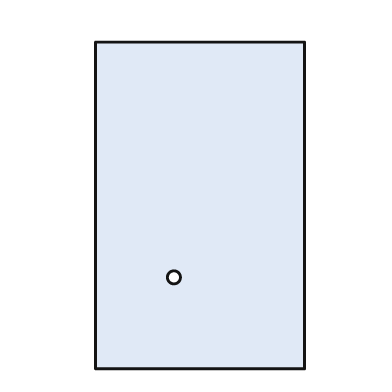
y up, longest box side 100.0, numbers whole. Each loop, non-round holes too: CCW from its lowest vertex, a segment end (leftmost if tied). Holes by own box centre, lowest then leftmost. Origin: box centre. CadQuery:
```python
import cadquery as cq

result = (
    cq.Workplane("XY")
    .moveTo(-32.0, -50.0)
    .lineTo(32.0, -50.0)
    .lineTo(32.0, 50.0)
    .lineTo(-32.0, 50.0)
    .close()
    .moveTo(-8.0, -22.0)
    .circle(2.0)
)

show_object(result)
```